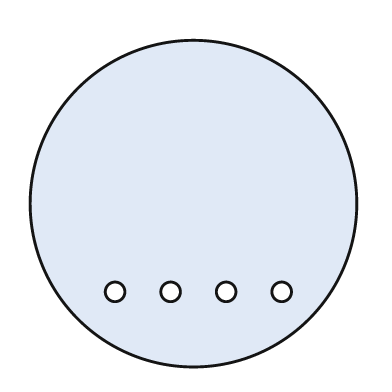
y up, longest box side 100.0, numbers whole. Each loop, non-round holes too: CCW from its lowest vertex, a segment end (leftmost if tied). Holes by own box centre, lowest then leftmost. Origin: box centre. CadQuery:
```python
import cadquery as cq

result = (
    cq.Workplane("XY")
    .moveTo(0.0, 0.0)
    .circle(50.0)
    .moveTo(-24.0, -27.0)
    .circle(3.0)
    .moveTo(-7.0, -27.0)
    .circle(3.0)
    .moveTo(10.0, -27.0)
    .circle(3.0)
    .moveTo(27.0, -27.0)
    .circle(3.0)
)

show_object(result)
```